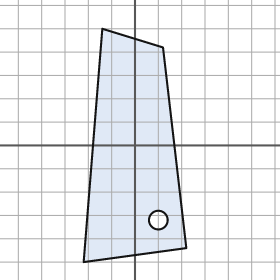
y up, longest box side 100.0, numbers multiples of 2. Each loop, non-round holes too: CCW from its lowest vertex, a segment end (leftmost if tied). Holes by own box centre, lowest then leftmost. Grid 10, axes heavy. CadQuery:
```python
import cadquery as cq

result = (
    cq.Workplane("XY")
    .moveTo(-22.0, -50.0)
    .lineTo(22.0, -44.0)
    .lineTo(12.0, 42.0)
    .lineTo(-14.0, 50.0)
    .close()
    .moveTo(10.0, -32.0)
    .circle(4.0)
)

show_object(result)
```